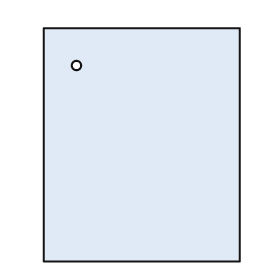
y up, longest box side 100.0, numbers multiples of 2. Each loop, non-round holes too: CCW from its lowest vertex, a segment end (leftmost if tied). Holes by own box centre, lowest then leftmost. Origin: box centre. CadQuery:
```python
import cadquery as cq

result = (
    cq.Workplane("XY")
    .moveTo(-42.0, -50.0)
    .lineTo(42.0, -50.0)
    .lineTo(42.0, 50.0)
    .lineTo(-42.0, 50.0)
    .close()
    .moveTo(-28.0, 34.0)
    .circle(2.0)
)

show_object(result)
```